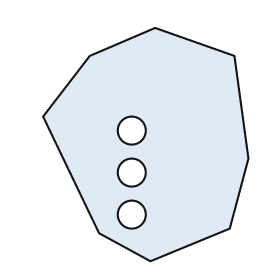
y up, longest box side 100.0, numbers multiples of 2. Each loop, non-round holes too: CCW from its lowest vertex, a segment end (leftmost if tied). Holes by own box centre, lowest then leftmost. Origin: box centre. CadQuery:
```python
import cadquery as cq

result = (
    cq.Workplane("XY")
    .moveTo(2.0, -50.0)
    .lineTo(36.0, -36.0)
    .lineTo(44.0, -6.0)
    .lineTo(38.0, 38.0)
    .lineTo(4.0, 50.0)
    .lineTo(-24.0, 38.0)
    .lineTo(-44.0, 12.0)
    .lineTo(-20.0, -38.0)
    .close()
    .moveTo(-6.0, -30.0)
    .circle(6.0)
    .moveTo(-6.0, -12.0)
    .circle(6.0)
    .moveTo(-6.0, 6.0)
    .circle(6.0)
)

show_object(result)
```